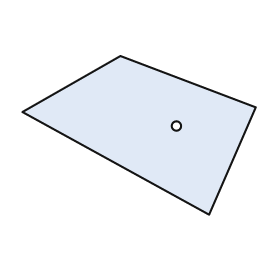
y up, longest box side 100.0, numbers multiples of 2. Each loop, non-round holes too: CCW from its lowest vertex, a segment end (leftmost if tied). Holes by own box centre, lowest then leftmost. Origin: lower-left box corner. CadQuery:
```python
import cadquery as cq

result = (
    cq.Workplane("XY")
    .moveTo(80.0, 0.0)
    .lineTo(100.0, 46.0)
    .lineTo(42.0, 68.0)
    .lineTo(0.0, 44.0)
    .close()
    .moveTo(66.0, 38.0)
    .circle(2.0)
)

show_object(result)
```